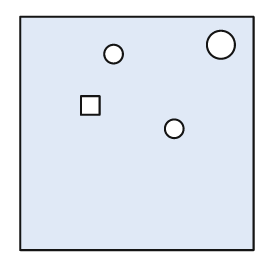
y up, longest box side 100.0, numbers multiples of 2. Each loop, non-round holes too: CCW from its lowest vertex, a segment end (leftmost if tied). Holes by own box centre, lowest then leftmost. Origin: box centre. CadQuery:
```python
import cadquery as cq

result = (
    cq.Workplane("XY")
    .moveTo(-50.0, -50.0)
    .lineTo(50.0, -50.0)
    .lineTo(50.0, 50.0)
    .lineTo(-50.0, 50.0)
    .close()
    .moveTo(16.0, 2.0)
    .circle(4.0)
    .moveTo(-24.0, 8.0)
    .lineTo(-16.0, 8.0)
    .lineTo(-16.0, 16.0)
    .lineTo(-24.0, 16.0)
    .close()
    .moveTo(-10.0, 34.0)
    .circle(4.0)
    .moveTo(36.0, 38.0)
    .circle(6.0)
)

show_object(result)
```